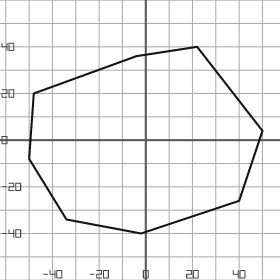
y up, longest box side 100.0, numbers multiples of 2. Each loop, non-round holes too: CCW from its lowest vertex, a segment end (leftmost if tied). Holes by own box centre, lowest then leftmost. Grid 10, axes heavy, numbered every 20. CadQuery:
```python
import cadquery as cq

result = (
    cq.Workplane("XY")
    .moveTo(-2.0, -40.0)
    .lineTo(40.0, -26.0)
    .lineTo(50.0, 4.0)
    .lineTo(22.0, 40.0)
    .lineTo(-4.0, 36.0)
    .lineTo(-48.0, 20.0)
    .lineTo(-50.0, -8.0)
    .lineTo(-34.0, -34.0)
    .close()
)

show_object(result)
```